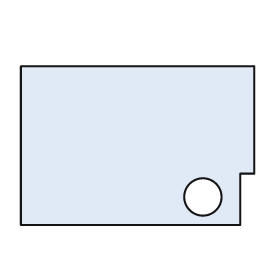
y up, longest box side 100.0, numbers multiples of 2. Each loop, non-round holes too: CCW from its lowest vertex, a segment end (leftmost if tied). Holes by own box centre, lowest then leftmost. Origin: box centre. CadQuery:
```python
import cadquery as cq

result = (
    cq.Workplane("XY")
    .moveTo(-50.0, -34.0)
    .lineTo(44.0, -34.0)
    .lineTo(44.0, -12.0)
    .lineTo(50.0, -12.0)
    .lineTo(50.0, 34.0)
    .lineTo(-50.0, 34.0)
    .close()
    .moveTo(28.0, -22.0)
    .circle(8.0)
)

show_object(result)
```